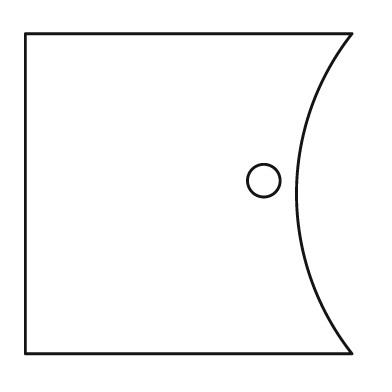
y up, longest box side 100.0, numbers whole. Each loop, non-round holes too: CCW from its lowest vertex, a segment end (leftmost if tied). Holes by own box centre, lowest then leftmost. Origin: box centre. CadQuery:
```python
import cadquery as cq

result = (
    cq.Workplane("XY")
    .moveTo(-50.0, -49.0)
    .lineTo(50.0, -49.0)
    .threePointArc((33.0, 0.0), (50.0, 49.0))
    .lineTo(-50.0, 49.0)
    .close()
    .moveTo(23.0, 4.0)
    .circle(5.0)
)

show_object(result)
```